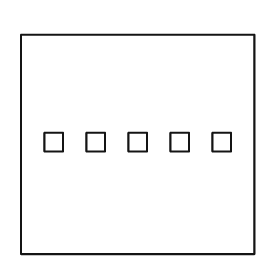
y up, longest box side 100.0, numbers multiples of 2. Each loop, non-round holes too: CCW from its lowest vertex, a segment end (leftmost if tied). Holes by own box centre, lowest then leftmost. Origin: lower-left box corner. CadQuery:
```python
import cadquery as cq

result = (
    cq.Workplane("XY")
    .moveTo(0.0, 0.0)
    .lineTo(100.0, 0.0)
    .lineTo(100.0, 94.0)
    .lineTo(0.0, 94.0)
    .close()
    .moveTo(10.0, 44.0)
    .lineTo(18.0, 44.0)
    .lineTo(18.0, 52.0)
    .lineTo(10.0, 52.0)
    .close()
    .moveTo(28.0, 44.0)
    .lineTo(36.0, 44.0)
    .lineTo(36.0, 52.0)
    .lineTo(28.0, 52.0)
    .close()
    .moveTo(46.0, 44.0)
    .lineTo(54.0, 44.0)
    .lineTo(54.0, 52.0)
    .lineTo(46.0, 52.0)
    .close()
    .moveTo(64.0, 44.0)
    .lineTo(72.0, 44.0)
    .lineTo(72.0, 52.0)
    .lineTo(64.0, 52.0)
    .close()
    .moveTo(82.0, 44.0)
    .lineTo(90.0, 44.0)
    .lineTo(90.0, 52.0)
    .lineTo(82.0, 52.0)
    .close()
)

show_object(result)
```